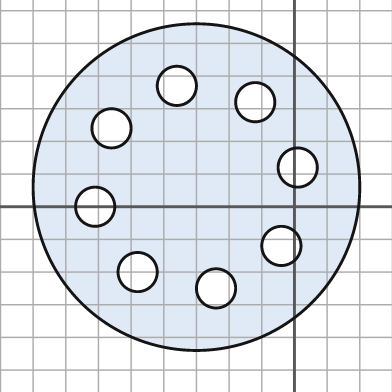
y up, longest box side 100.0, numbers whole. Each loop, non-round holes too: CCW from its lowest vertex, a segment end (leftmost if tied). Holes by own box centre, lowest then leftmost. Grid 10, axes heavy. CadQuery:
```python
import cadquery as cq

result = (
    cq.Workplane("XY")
    .moveTo(-30.0, 6.0)
    .circle(50.0)
    .moveTo(-24.0, -25.0)
    .circle(6.0)
    .moveTo(-48.0, -20.0)
    .circle(6.0)
    .moveTo(-4.0, -12.0)
    .circle(6.0)
    .moveTo(-61.0, 0.0)
    .circle(6.0)
    .moveTo(1.0, 12.0)
    .circle(6.0)
    .moveTo(-56.0, 24.0)
    .circle(6.0)
    .moveTo(-12.0, 32.0)
    .circle(6.0)
    .moveTo(-36.0, 37.0)
    .circle(6.0)
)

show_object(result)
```